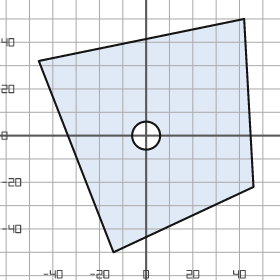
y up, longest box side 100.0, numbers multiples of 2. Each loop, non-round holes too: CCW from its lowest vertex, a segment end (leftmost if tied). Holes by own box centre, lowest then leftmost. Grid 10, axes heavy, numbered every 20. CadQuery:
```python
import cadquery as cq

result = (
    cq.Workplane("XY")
    .moveTo(-14.0, -50.0)
    .lineTo(46.0, -22.0)
    .lineTo(42.0, 50.0)
    .lineTo(-46.0, 32.0)
    .close()
    .moveTo(0.0, 0.0)
    .circle(6.0)
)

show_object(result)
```